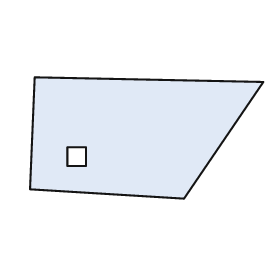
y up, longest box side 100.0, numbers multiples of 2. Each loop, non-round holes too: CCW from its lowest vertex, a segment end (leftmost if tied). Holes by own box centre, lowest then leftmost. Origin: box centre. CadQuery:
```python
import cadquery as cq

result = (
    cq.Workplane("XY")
    .moveTo(16.0, -26.0)
    .lineTo(50.0, 24.0)
    .lineTo(-48.0, 26.0)
    .lineTo(-50.0, -22.0)
    .close()
    .moveTo(-34.0, -12.0)
    .lineTo(-26.0, -12.0)
    .lineTo(-26.0, -4.0)
    .lineTo(-34.0, -4.0)
    .close()
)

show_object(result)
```